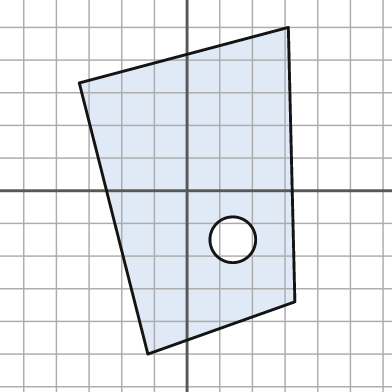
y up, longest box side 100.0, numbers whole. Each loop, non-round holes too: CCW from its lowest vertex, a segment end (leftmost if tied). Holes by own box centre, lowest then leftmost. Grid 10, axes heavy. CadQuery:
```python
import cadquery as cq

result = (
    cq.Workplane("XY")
    .moveTo(-12.0, -50.0)
    .lineTo(33.0, -34.0)
    .lineTo(31.0, 50.0)
    .lineTo(-33.0, 33.0)
    .close()
    .moveTo(14.0, -15.0)
    .circle(7.0)
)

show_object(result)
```